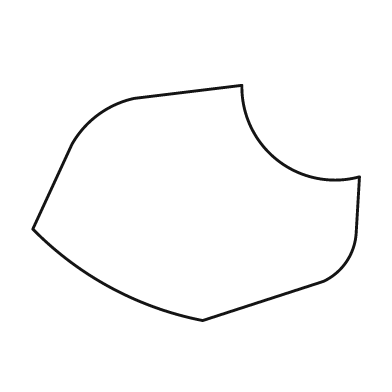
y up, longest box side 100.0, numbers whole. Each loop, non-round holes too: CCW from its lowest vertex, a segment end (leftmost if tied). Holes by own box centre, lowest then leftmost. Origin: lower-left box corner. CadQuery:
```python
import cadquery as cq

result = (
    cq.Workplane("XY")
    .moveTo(52.0, 0.0)
    .lineTo(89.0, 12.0)
    .threePointArc((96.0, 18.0), (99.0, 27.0))
    .lineTo(100.0, 44.0)
    .threePointArc((75.0, 49.0), (64.0, 72.0))
    .lineTo(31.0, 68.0)
    .threePointArc((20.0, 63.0), (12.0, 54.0))
    .lineTo(0.0, 28.0)
    .threePointArc((24.0, 10.0), (52.0, 0.0))
    .close()
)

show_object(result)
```